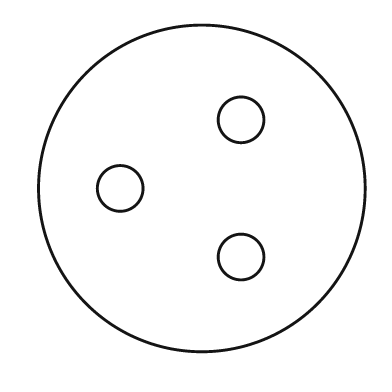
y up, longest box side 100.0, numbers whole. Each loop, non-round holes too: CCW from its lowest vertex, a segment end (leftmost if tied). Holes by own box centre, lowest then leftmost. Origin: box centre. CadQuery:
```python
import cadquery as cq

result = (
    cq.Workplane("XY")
    .moveTo(0.0, 0.0)
    .circle(50.0)
    .moveTo(12.0, -21.0)
    .circle(7.0)
    .moveTo(-25.0, 0.0)
    .circle(7.0)
    .moveTo(12.0, 21.0)
    .circle(7.0)
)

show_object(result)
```